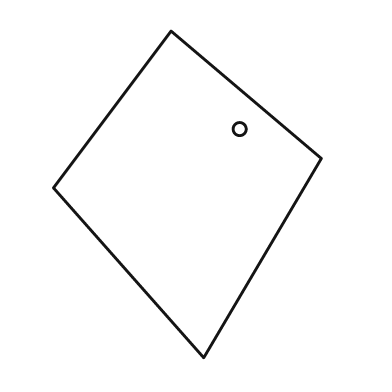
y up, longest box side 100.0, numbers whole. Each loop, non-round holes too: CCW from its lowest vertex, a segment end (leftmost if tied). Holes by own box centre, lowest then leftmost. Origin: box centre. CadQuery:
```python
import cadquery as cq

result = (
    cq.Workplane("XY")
    .moveTo(5.0, -50.0)
    .lineTo(41.0, 11.0)
    .lineTo(-5.0, 50.0)
    .lineTo(-41.0, 2.0)
    .close()
    .moveTo(16.0, 20.0)
    .circle(2.0)
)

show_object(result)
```